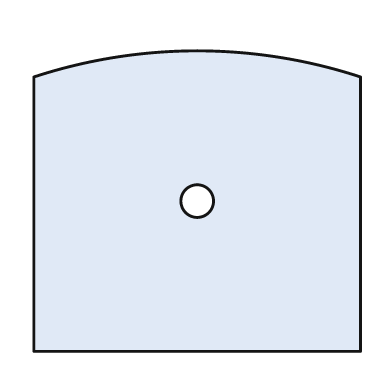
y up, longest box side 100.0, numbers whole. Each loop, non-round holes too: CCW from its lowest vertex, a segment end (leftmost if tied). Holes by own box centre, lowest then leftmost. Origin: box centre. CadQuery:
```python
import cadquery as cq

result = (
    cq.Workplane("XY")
    .moveTo(-50.0, -46.0)
    .lineTo(50.0, -46.0)
    .lineTo(50.0, 38.0)
    .threePointArc((0.0, 46.0), (-50.0, 38.0))
    .close()
    .moveTo(0.0, 0.0)
    .circle(5.0)
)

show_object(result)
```